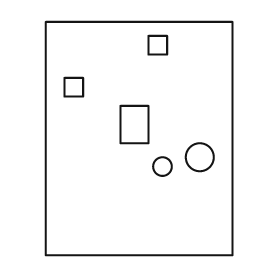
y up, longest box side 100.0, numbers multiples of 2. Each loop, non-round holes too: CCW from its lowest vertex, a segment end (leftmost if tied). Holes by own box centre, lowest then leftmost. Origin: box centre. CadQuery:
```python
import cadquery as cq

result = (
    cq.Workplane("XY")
    .moveTo(-40.0, -50.0)
    .lineTo(40.0, -50.0)
    .lineTo(40.0, 50.0)
    .lineTo(-40.0, 50.0)
    .close()
    .moveTo(10.0, -12.0)
    .circle(4.0)
    .moveTo(26.0, -8.0)
    .circle(6.0)
    .moveTo(-8.0, -2.0)
    .lineTo(4.0, -2.0)
    .lineTo(4.0, 14.0)
    .lineTo(-8.0, 14.0)
    .close()
    .moveTo(-32.0, 18.0)
    .lineTo(-24.0, 18.0)
    .lineTo(-24.0, 26.0)
    .lineTo(-32.0, 26.0)
    .close()
    .moveTo(4.0, 36.0)
    .lineTo(12.0, 36.0)
    .lineTo(12.0, 44.0)
    .lineTo(4.0, 44.0)
    .close()
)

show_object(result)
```